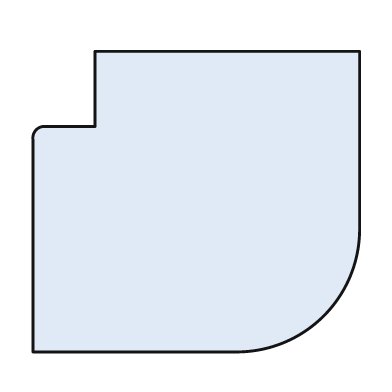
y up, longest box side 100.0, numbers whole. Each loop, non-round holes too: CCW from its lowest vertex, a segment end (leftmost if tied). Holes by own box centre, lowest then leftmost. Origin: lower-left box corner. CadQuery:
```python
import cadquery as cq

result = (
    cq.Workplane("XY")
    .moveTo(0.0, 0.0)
    .lineTo(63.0, 0.0)
    .threePointArc((89.0, 11.0), (100.0, 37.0))
    .lineTo(100.0, 92.0)
    .lineTo(19.0, 92.0)
    .lineTo(19.0, 69.0)
    .lineTo(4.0, 69.0)
    .threePointArc((1.0, 68.0), (0.0, 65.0))
    .close()
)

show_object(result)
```